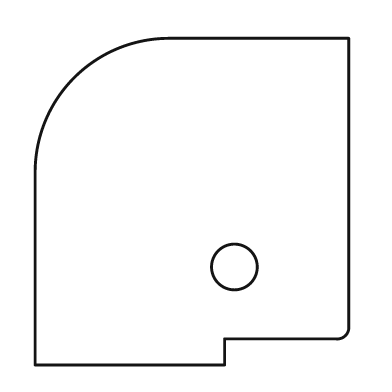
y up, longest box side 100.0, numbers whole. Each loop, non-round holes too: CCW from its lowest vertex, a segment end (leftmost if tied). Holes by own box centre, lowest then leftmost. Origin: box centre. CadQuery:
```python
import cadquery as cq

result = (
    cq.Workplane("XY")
    .moveTo(-48.0, -50.0)
    .lineTo(10.0, -50.0)
    .lineTo(10.0, -42.0)
    .lineTo(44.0, -42.0)
    .threePointArc((47.0, -41.0), (48.0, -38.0))
    .lineTo(48.0, 50.0)
    .lineTo(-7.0, 50.0)
    .threePointArc((-36.0, 38.0), (-48.0, 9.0))
    .close()
    .moveTo(13.0, -20.0)
    .circle(7.0)
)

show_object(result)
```